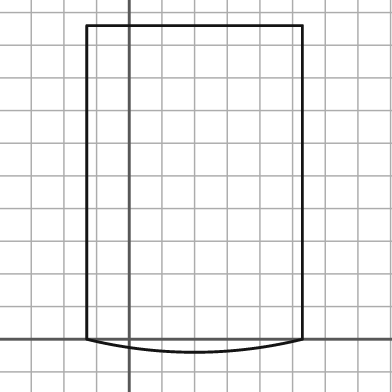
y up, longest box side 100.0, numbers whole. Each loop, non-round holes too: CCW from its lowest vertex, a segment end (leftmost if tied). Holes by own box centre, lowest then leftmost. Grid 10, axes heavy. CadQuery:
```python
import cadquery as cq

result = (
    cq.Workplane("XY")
    .moveTo(-13.0, 0.0)
    .threePointArc((20.0, -4.0), (53.0, 0.0))
    .lineTo(53.0, 96.0)
    .lineTo(-13.0, 96.0)
    .close()
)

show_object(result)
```